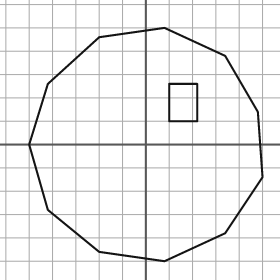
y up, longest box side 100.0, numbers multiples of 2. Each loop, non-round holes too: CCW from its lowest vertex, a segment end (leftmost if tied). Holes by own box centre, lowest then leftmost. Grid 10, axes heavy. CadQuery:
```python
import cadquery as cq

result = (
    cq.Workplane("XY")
    .moveTo(8.0, -50.0)
    .lineTo(34.0, -38.0)
    .lineTo(50.0, -14.0)
    .lineTo(48.0, 14.0)
    .lineTo(34.0, 38.0)
    .lineTo(8.0, 50.0)
    .lineTo(-20.0, 46.0)
    .lineTo(-42.0, 26.0)
    .lineTo(-50.0, 0.0)
    .lineTo(-42.0, -28.0)
    .lineTo(-20.0, -46.0)
    .close()
    .moveTo(10.0, 10.0)
    .lineTo(22.0, 10.0)
    .lineTo(22.0, 26.0)
    .lineTo(10.0, 26.0)
    .close()
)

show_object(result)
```